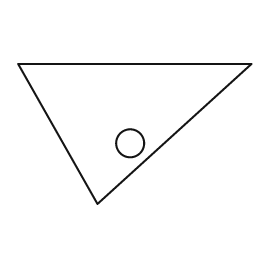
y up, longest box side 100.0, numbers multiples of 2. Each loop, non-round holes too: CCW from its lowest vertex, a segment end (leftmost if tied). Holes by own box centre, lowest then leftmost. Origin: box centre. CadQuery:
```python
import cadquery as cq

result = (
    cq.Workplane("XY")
    .moveTo(-16.0, -30.0)
    .lineTo(50.0, 30.0)
    .lineTo(-50.0, 30.0)
    .close()
    .moveTo(-2.0, -4.0)
    .circle(6.0)
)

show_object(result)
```